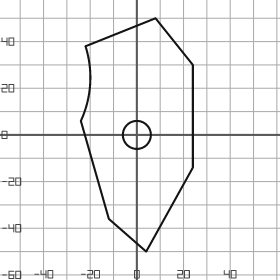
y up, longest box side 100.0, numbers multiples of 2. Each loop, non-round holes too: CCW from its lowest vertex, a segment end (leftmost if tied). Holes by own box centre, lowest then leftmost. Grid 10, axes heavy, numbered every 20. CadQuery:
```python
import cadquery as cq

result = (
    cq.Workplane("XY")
    .moveTo(4.0, -50.0)
    .lineTo(24.0, -14.0)
    .lineTo(24.0, 30.0)
    .lineTo(8.0, 50.0)
    .lineTo(-22.0, 38.0)
    .threePointArc((-20.0, 22.0), (-24.0, 6.0))
    .lineTo(-12.0, -36.0)
    .close()
    .moveTo(0.0, 0.0)
    .circle(6.0)
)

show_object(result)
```